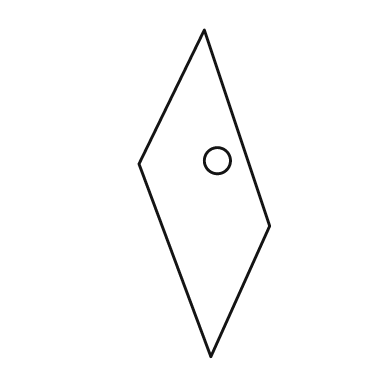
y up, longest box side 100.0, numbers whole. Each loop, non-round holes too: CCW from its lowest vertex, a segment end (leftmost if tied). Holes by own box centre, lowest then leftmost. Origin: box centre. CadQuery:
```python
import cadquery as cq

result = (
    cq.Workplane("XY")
    .moveTo(2.0, -50.0)
    .lineTo(20.0, -10.0)
    .lineTo(0.0, 50.0)
    .lineTo(-20.0, 9.0)
    .close()
    .moveTo(4.0, 10.0)
    .circle(4.0)
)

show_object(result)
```